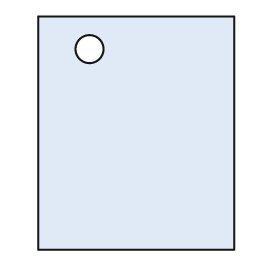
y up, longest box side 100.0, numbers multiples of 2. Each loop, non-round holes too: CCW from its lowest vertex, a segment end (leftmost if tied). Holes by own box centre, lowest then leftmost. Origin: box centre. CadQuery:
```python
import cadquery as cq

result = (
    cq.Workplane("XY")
    .moveTo(-42.0, -50.0)
    .lineTo(42.0, -50.0)
    .lineTo(42.0, 50.0)
    .lineTo(-42.0, 50.0)
    .close()
    .moveTo(-20.0, 36.0)
    .circle(6.0)
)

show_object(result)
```